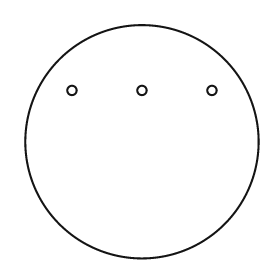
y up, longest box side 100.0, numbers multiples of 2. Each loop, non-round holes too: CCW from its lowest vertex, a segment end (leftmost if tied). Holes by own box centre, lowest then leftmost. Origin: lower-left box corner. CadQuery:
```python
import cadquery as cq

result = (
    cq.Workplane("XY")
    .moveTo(50.0, 50.0)
    .circle(50.0)
    .moveTo(20.0, 72.0)
    .circle(2.0)
    .moveTo(50.0, 72.0)
    .circle(2.0)
    .moveTo(80.0, 72.0)
    .circle(2.0)
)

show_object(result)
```